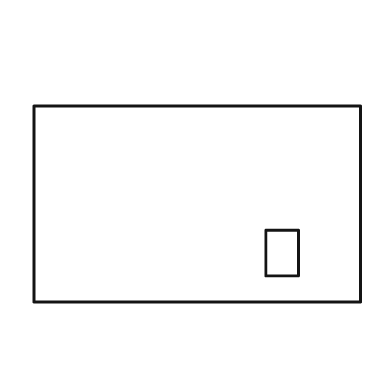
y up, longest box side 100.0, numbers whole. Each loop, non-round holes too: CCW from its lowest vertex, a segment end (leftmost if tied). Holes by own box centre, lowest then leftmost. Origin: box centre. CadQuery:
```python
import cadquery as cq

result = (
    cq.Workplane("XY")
    .moveTo(-50.0, -30.0)
    .lineTo(50.0, -30.0)
    .lineTo(50.0, 30.0)
    .lineTo(-50.0, 30.0)
    .close()
    .moveTo(21.0, -22.0)
    .lineTo(31.0, -22.0)
    .lineTo(31.0, -8.0)
    .lineTo(21.0, -8.0)
    .close()
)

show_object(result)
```